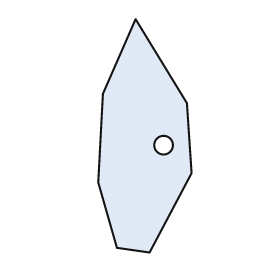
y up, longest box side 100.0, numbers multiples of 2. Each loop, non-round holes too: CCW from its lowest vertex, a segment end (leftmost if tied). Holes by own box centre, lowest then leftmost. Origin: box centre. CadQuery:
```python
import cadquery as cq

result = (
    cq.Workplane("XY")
    .moveTo(2.0, -50.0)
    .lineTo(20.0, -16.0)
    .lineTo(18.0, 14.0)
    .lineTo(-4.0, 50.0)
    .lineTo(-18.0, 18.0)
    .lineTo(-20.0, -20.0)
    .lineTo(-12.0, -48.0)
    .close()
    .moveTo(8.0, -4.0)
    .circle(4.0)
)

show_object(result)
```